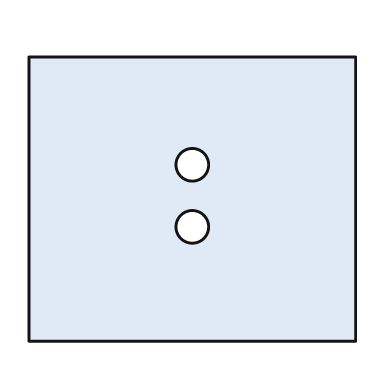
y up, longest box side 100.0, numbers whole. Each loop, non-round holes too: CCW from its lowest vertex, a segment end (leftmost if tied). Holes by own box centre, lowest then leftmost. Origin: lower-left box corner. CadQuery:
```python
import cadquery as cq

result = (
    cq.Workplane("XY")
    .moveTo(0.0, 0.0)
    .lineTo(100.0, 0.0)
    .lineTo(100.0, 87.0)
    .lineTo(0.0, 87.0)
    .close()
    .moveTo(50.0, 35.0)
    .circle(5.0)
    .moveTo(50.0, 54.0)
    .circle(5.0)
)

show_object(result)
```